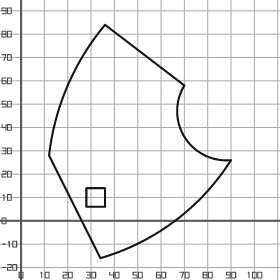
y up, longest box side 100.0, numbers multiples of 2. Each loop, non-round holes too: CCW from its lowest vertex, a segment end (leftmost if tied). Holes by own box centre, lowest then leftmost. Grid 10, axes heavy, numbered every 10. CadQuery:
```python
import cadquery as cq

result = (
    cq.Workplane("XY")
    .moveTo(34.0, -16.0)
    .threePointArc((66.0, 0.0), (90.0, 26.0))
    .threePointArc((70.0, 36.0), (70.0, 58.0))
    .lineTo(36.0, 84.0)
    .threePointArc((20.0, 58.0), (12.0, 28.0))
    .close()
    .moveTo(28.0, 6.0)
    .lineTo(36.0, 6.0)
    .lineTo(36.0, 14.0)
    .lineTo(28.0, 14.0)
    .close()
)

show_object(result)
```